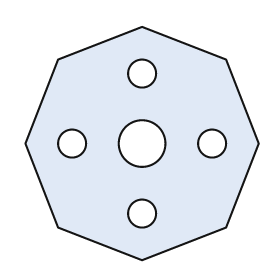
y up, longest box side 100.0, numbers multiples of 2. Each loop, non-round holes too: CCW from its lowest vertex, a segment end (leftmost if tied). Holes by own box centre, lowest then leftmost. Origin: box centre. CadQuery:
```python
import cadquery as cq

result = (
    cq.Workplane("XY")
    .moveTo(0.0, -50.0)
    .lineTo(36.0, -36.0)
    .lineTo(50.0, 0.0)
    .lineTo(36.0, 36.0)
    .lineTo(0.0, 50.0)
    .lineTo(-36.0, 36.0)
    .lineTo(-50.0, 0.0)
    .lineTo(-36.0, -36.0)
    .close()
    .moveTo(0.0, -30.0)
    .circle(6.0)
    .moveTo(-30.0, 0.0)
    .circle(6.0)
    .moveTo(0.0, 0.0)
    .circle(10.0)
    .moveTo(30.0, 0.0)
    .circle(6.0)
    .moveTo(0.0, 30.0)
    .circle(6.0)
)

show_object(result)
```